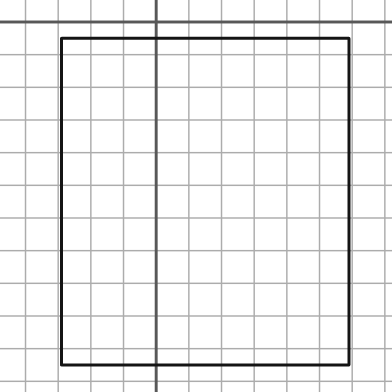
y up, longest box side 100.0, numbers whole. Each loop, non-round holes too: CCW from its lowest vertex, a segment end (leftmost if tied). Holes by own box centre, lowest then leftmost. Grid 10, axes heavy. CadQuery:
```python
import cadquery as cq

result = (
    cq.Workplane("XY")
    .moveTo(-29.0, -105.0)
    .lineTo(59.0, -105.0)
    .lineTo(59.0, -5.0)
    .lineTo(-29.0, -5.0)
    .close()
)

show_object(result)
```